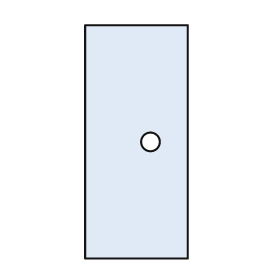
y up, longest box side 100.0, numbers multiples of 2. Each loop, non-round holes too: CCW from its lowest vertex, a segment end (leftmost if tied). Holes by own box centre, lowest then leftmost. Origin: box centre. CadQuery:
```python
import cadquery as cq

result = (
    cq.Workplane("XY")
    .moveTo(-22.0, -50.0)
    .lineTo(22.0, -50.0)
    .lineTo(22.0, 50.0)
    .lineTo(-22.0, 50.0)
    .close()
    .moveTo(6.0, 0.0)
    .circle(4.0)
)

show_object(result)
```